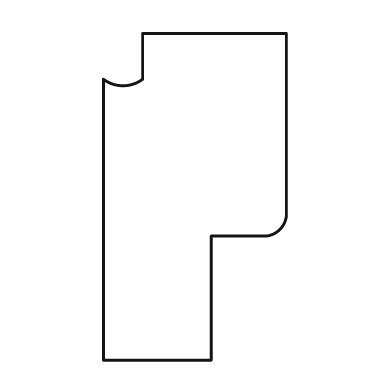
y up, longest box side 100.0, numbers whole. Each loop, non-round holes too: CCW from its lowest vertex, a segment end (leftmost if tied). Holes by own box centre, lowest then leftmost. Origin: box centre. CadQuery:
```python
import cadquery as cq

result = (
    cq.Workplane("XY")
    .moveTo(-28.0, -50.0)
    .lineTo(5.0, -50.0)
    .lineTo(5.0, -12.0)
    .lineTo(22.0, -12.0)
    .threePointArc((26.0, -10.0), (28.0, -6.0))
    .lineTo(28.0, 50.0)
    .lineTo(-16.0, 50.0)
    .lineTo(-16.0, 36.0)
    .threePointArc((-22.0, 34.0), (-28.0, 36.0))
    .close()
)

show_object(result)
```